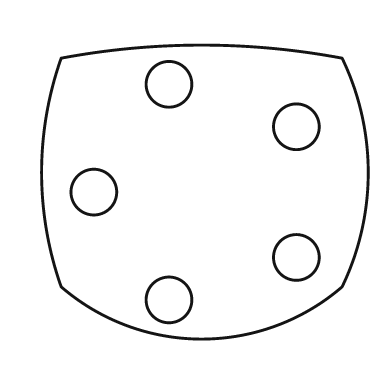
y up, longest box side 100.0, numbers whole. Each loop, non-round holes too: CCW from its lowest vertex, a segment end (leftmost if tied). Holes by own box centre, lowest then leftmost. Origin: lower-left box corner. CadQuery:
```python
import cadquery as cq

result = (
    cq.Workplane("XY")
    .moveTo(6.0, 16.0)
    .threePointArc((49.0, 0.0), (92.0, 16.0))
    .threePointArc((100.0, 51.0), (92.0, 86.0))
    .threePointArc((49.0, 90.0), (6.0, 86.0))
    .threePointArc((0.0, 51.0), (6.0, 16.0))
    .close()
    .moveTo(39.0, 12.0)
    .circle(7.0)
    .moveTo(78.0, 25.0)
    .circle(7.0)
    .moveTo(16.0, 45.0)
    .circle(7.0)
    .moveTo(78.0, 65.0)
    .circle(7.0)
    .moveTo(39.0, 78.0)
    .circle(7.0)
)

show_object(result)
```